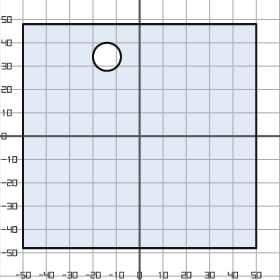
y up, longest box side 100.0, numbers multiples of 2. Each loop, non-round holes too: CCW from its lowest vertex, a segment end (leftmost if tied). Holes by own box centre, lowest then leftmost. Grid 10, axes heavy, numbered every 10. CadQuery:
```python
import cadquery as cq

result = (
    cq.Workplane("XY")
    .moveTo(-50.0, -48.0)
    .lineTo(50.0, -48.0)
    .lineTo(50.0, 48.0)
    .lineTo(-50.0, 48.0)
    .close()
    .moveTo(-14.0, 34.0)
    .circle(6.0)
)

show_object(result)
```